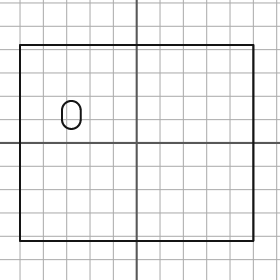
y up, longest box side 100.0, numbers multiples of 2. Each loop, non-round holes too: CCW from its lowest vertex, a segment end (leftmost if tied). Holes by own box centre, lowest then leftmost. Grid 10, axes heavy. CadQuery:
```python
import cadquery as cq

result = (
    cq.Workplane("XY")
    .moveTo(-50.0, -42.0)
    .lineTo(50.0, -42.0)
    .lineTo(50.0, 42.0)
    .lineTo(-50.0, 42.0)
    .close()
    .moveTo(-32.0, 10.0)
    .threePointArc((-28.0, 6.0), (-24.0, 10.0))
    .lineTo(-24.0, 14.0)
    .threePointArc((-28.0, 18.0), (-32.0, 14.0))
    .close()
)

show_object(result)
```